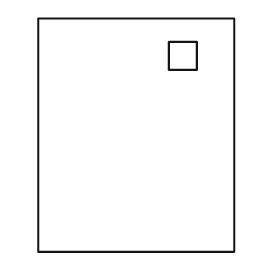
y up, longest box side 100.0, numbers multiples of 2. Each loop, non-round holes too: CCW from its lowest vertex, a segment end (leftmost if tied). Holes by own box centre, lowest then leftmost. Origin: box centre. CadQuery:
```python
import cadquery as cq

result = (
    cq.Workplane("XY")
    .moveTo(-42.0, -50.0)
    .lineTo(42.0, -50.0)
    .lineTo(42.0, 50.0)
    .lineTo(-42.0, 50.0)
    .close()
    .moveTo(14.0, 28.0)
    .lineTo(26.0, 28.0)
    .lineTo(26.0, 40.0)
    .lineTo(14.0, 40.0)
    .close()
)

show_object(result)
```